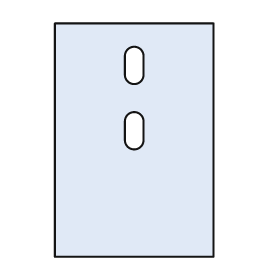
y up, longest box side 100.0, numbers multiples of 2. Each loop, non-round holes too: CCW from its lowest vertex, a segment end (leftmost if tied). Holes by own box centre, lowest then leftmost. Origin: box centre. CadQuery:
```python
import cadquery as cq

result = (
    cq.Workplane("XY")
    .moveTo(-34.0, -50.0)
    .lineTo(34.0, -50.0)
    .lineTo(34.0, 50.0)
    .lineTo(-34.0, 50.0)
    .close()
    .moveTo(-4.0, 0.0)
    .threePointArc((0.0, -4.0), (4.0, 0.0))
    .lineTo(4.0, 8.0)
    .threePointArc((0.0, 12.0), (-4.0, 8.0))
    .close()
    .moveTo(-4.0, 28.0)
    .threePointArc((0.0, 24.0), (4.0, 28.0))
    .lineTo(4.0, 36.0)
    .threePointArc((0.0, 40.0), (-4.0, 36.0))
    .close()
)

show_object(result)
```